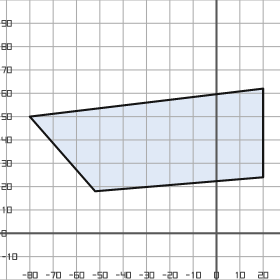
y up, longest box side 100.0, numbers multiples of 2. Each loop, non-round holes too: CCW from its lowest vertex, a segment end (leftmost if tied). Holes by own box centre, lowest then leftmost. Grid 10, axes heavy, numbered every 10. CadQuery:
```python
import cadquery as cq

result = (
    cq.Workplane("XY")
    .moveTo(-52.0, 18.0)
    .lineTo(20.0, 24.0)
    .lineTo(20.0, 62.0)
    .lineTo(-80.0, 50.0)
    .close()
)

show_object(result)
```